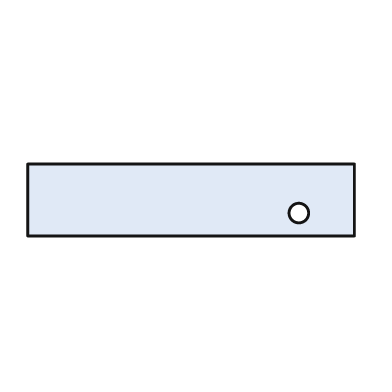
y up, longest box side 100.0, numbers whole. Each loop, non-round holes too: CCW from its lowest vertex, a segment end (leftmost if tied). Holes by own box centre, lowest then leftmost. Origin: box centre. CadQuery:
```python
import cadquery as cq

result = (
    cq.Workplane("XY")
    .moveTo(-50.0, -11.0)
    .lineTo(50.0, -11.0)
    .lineTo(50.0, 11.0)
    .lineTo(-50.0, 11.0)
    .close()
    .moveTo(33.0, -4.0)
    .circle(3.0)
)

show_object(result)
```